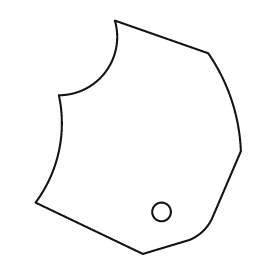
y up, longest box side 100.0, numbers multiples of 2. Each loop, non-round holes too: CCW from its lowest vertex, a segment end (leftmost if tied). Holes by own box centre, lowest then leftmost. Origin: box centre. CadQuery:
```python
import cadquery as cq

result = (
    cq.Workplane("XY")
    .moveTo(2.0, -50.0)
    .lineTo(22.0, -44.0)
    .threePointArc((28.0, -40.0), (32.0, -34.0))
    .lineTo(44.0, -6.0)
    .threePointArc((40.0, 16.0), (30.0, 36.0))
    .lineTo(-10.0, 50.0)
    .threePointArc((-14.0, 28.0), (-34.0, 18.0))
    .threePointArc((-34.0, -6.0), (-44.0, -28.0))
    .close()
    .moveTo(10.0, -32.0)
    .circle(4.0)
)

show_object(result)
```